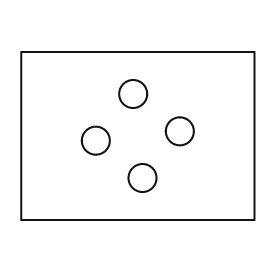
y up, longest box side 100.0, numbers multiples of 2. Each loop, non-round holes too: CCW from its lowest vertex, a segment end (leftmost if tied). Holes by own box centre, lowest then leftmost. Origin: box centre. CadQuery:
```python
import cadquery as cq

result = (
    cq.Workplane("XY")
    .moveTo(-50.0, -36.0)
    .lineTo(50.0, -36.0)
    .lineTo(50.0, 36.0)
    .lineTo(-50.0, 36.0)
    .close()
    .moveTo(2.0, -18.0)
    .circle(6.0)
    .moveTo(-18.0, -2.0)
    .circle(6.0)
    .moveTo(18.0, 2.0)
    .circle(6.0)
    .moveTo(-2.0, 18.0)
    .circle(6.0)
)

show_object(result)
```